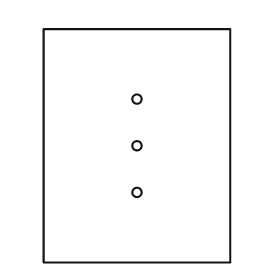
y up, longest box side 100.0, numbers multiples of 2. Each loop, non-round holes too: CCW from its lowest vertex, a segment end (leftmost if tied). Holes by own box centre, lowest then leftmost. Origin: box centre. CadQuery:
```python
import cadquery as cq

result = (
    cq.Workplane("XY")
    .moveTo(-40.0, -50.0)
    .lineTo(40.0, -50.0)
    .lineTo(40.0, 50.0)
    .lineTo(-40.0, 50.0)
    .close()
    .moveTo(0.0, -20.0)
    .circle(2.0)
    .moveTo(0.0, 0.0)
    .circle(2.0)
    .moveTo(0.0, 20.0)
    .circle(2.0)
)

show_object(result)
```